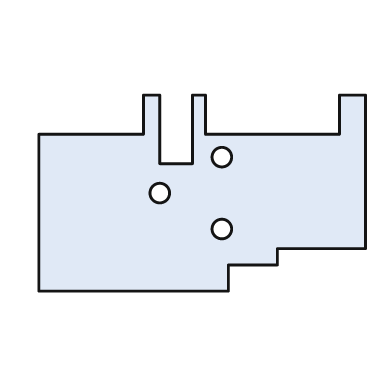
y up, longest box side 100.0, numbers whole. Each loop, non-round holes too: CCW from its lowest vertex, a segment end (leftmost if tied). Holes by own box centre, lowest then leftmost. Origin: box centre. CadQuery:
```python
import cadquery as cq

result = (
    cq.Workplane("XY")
    .moveTo(-50.0, -30.0)
    .lineTo(8.0, -30.0)
    .lineTo(8.0, -22.0)
    .lineTo(23.0, -22.0)
    .lineTo(23.0, -17.0)
    .lineTo(50.0, -17.0)
    .lineTo(50.0, 30.0)
    .lineTo(42.0, 30.0)
    .lineTo(42.0, 18.0)
    .lineTo(1.0, 18.0)
    .lineTo(1.0, 30.0)
    .lineTo(-3.0, 30.0)
    .lineTo(-3.0, 9.0)
    .lineTo(-13.0, 9.0)
    .lineTo(-13.0, 30.0)
    .lineTo(-18.0, 30.0)
    .lineTo(-18.0, 18.0)
    .lineTo(-50.0, 18.0)
    .close()
    .moveTo(6.0, -11.0)
    .circle(3.0)
    .moveTo(-13.0, 0.0)
    .circle(3.0)
    .moveTo(6.0, 11.0)
    .circle(3.0)
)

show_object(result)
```